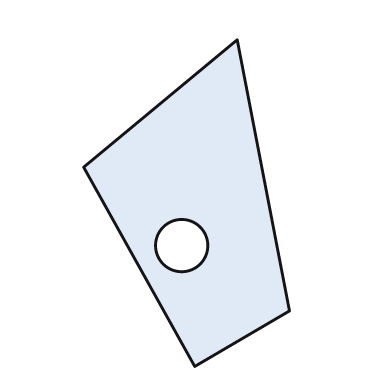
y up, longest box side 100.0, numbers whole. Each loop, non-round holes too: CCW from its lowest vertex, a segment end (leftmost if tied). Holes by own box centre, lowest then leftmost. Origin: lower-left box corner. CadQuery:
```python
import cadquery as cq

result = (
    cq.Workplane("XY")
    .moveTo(34.0, 0.0)
    .lineTo(63.0, 17.0)
    .lineTo(47.0, 100.0)
    .lineTo(0.0, 61.0)
    .close()
    .moveTo(30.0, 37.0)
    .circle(8.0)
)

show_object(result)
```